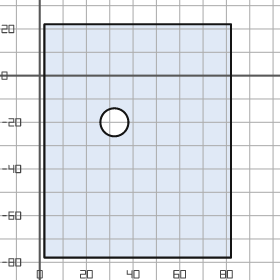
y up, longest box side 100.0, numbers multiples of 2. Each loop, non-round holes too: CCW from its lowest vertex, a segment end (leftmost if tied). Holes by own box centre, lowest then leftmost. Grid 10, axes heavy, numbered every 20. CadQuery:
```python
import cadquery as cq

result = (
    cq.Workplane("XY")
    .moveTo(2.0, -78.0)
    .lineTo(82.0, -78.0)
    .lineTo(82.0, 22.0)
    .lineTo(2.0, 22.0)
    .close()
    .moveTo(32.0, -20.0)
    .circle(6.0)
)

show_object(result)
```